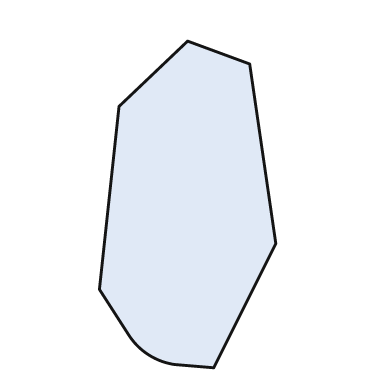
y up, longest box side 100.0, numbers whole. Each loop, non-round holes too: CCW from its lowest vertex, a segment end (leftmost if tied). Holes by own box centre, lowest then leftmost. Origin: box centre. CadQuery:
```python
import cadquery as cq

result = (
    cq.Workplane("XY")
    .moveTo(8.0, -50.0)
    .lineTo(27.0, -12.0)
    .lineTo(19.0, 43.0)
    .lineTo(0.0, 50.0)
    .lineTo(-21.0, 30.0)
    .lineTo(-27.0, -26.0)
    .lineTo(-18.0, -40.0)
    .threePointArc((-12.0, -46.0), (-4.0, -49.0))
    .close()
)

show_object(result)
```